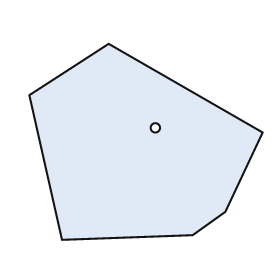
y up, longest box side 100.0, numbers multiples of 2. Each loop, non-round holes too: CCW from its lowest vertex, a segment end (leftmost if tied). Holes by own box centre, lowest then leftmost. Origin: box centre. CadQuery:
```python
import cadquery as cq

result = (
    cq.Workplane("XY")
    .moveTo(-36.0, -42.0)
    .lineTo(20.0, -40.0)
    .lineTo(34.0, -30.0)
    .lineTo(50.0, 4.0)
    .lineTo(-16.0, 42.0)
    .lineTo(-50.0, 20.0)
    .close()
    .moveTo(4.0, 6.0)
    .circle(2.0)
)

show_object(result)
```